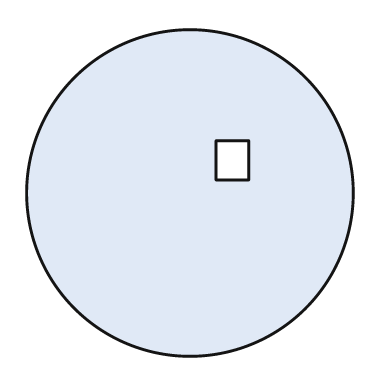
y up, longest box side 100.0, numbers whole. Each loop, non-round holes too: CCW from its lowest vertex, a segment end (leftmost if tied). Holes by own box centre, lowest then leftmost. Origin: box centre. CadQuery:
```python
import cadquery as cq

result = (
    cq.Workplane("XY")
    .moveTo(0.0, 0.0)
    .circle(50.0)
    .moveTo(8.0, 4.0)
    .lineTo(18.0, 4.0)
    .lineTo(18.0, 16.0)
    .lineTo(8.0, 16.0)
    .close()
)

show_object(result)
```